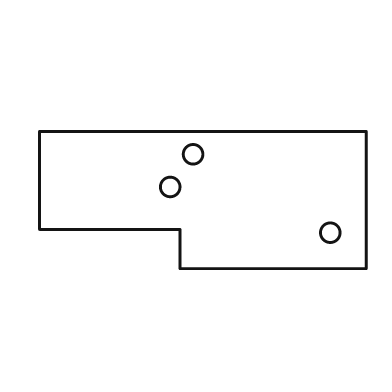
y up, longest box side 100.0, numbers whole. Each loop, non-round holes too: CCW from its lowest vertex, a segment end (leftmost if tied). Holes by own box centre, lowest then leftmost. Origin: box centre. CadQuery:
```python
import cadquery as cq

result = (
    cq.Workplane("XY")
    .moveTo(-7.0, -21.0)
    .lineTo(50.0, -21.0)
    .lineTo(50.0, 21.0)
    .lineTo(-50.0, 21.0)
    .lineTo(-50.0, -9.0)
    .lineTo(-7.0, -9.0)
    .close()
    .moveTo(39.0, -10.0)
    .circle(3.0)
    .moveTo(-10.0, 4.0)
    .circle(3.0)
    .moveTo(-3.0, 14.0)
    .circle(3.0)
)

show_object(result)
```